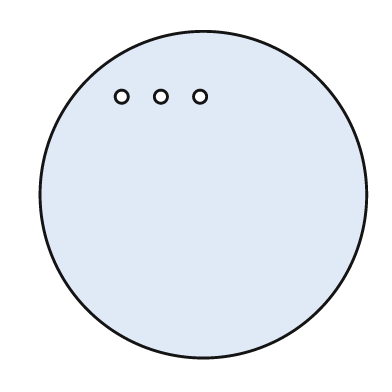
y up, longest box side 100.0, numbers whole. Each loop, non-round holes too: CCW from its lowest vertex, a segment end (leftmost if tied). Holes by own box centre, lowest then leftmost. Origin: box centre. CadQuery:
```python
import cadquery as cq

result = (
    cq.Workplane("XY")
    .moveTo(0.0, 0.0)
    .circle(50.0)
    .moveTo(-25.0, 30.0)
    .circle(2.0)
    .moveTo(-13.0, 30.0)
    .circle(2.0)
    .moveTo(-1.0, 30.0)
    .circle(2.0)
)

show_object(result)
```